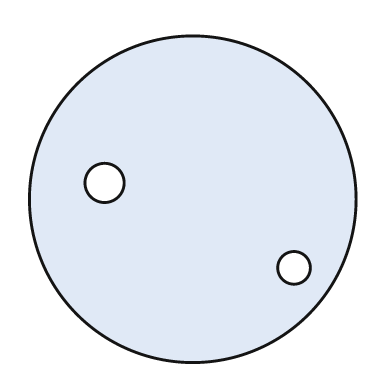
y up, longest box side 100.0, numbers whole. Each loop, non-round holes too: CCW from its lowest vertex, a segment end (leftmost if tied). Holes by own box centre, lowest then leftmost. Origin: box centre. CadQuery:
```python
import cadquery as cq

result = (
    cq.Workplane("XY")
    .moveTo(0.0, 0.0)
    .circle(50.0)
    .moveTo(31.0, -21.0)
    .circle(5.0)
    .moveTo(-27.0, 5.0)
    .circle(6.0)
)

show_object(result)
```